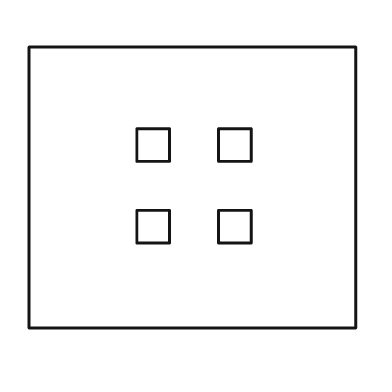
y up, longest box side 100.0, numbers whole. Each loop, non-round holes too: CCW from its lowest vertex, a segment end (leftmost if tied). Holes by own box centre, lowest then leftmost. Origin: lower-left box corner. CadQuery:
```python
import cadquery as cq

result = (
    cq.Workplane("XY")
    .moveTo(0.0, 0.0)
    .lineTo(100.0, 0.0)
    .lineTo(100.0, 86.0)
    .lineTo(0.0, 86.0)
    .close()
    .moveTo(33.0, 26.0)
    .lineTo(43.0, 26.0)
    .lineTo(43.0, 36.0)
    .lineTo(33.0, 36.0)
    .close()
    .moveTo(58.0, 26.0)
    .lineTo(68.0, 26.0)
    .lineTo(68.0, 36.0)
    .lineTo(58.0, 36.0)
    .close()
    .moveTo(33.0, 51.0)
    .lineTo(43.0, 51.0)
    .lineTo(43.0, 61.0)
    .lineTo(33.0, 61.0)
    .close()
    .moveTo(58.0, 51.0)
    .lineTo(68.0, 51.0)
    .lineTo(68.0, 61.0)
    .lineTo(58.0, 61.0)
    .close()
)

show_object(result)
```